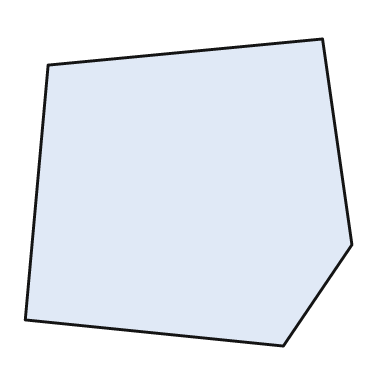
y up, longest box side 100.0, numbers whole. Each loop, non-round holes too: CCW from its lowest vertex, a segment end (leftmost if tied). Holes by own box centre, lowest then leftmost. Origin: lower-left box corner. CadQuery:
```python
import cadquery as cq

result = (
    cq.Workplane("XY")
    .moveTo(79.0, 0.0)
    .lineTo(100.0, 31.0)
    .lineTo(91.0, 94.0)
    .lineTo(7.0, 86.0)
    .lineTo(0.0, 8.0)
    .close()
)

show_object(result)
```